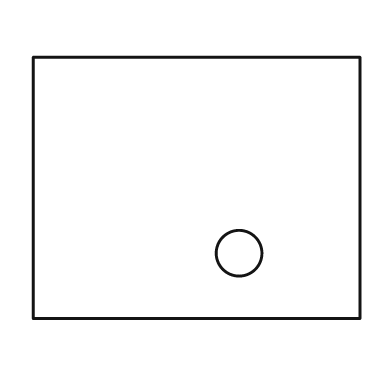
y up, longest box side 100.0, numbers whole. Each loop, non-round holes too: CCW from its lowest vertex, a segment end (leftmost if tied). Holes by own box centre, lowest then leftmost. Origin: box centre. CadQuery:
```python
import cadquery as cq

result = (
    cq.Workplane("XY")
    .moveTo(-50.0, -40.0)
    .lineTo(50.0, -40.0)
    .lineTo(50.0, 40.0)
    .lineTo(-50.0, 40.0)
    .close()
    .moveTo(13.0, -20.0)
    .circle(7.0)
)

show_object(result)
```